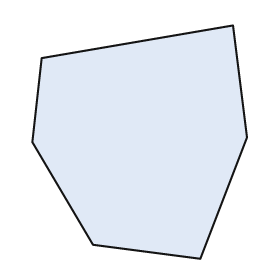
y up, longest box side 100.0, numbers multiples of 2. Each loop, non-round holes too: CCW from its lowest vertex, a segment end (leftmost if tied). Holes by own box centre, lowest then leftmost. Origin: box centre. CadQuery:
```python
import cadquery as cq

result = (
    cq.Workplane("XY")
    .moveTo(26.0, -50.0)
    .lineTo(46.0, 2.0)
    .lineTo(40.0, 50.0)
    .lineTo(-42.0, 36.0)
    .lineTo(-46.0, 0.0)
    .lineTo(-20.0, -44.0)
    .close()
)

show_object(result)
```